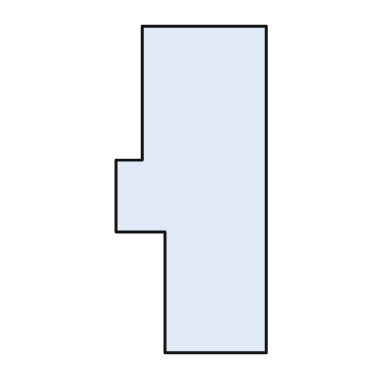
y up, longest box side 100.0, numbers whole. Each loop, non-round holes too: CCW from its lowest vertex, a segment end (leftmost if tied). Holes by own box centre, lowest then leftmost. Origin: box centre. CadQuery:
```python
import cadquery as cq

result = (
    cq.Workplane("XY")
    .moveTo(-8.0, -50.0)
    .lineTo(23.0, -50.0)
    .lineTo(23.0, 50.0)
    .lineTo(-15.0, 50.0)
    .lineTo(-15.0, 9.0)
    .lineTo(-23.0, 9.0)
    .lineTo(-23.0, -13.0)
    .lineTo(-8.0, -13.0)
    .close()
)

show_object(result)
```